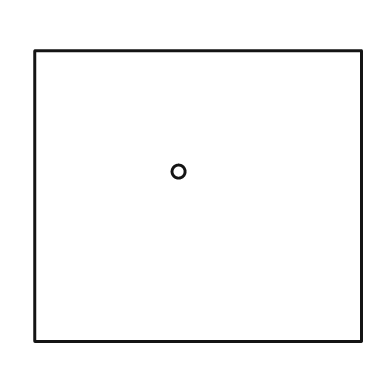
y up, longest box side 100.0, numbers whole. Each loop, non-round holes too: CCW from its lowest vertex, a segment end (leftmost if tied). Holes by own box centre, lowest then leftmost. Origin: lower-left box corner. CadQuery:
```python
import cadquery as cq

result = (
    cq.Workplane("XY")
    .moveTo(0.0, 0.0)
    .lineTo(100.0, 0.0)
    .lineTo(100.0, 89.0)
    .lineTo(0.0, 89.0)
    .close()
    .moveTo(44.0, 52.0)
    .circle(2.0)
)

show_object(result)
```